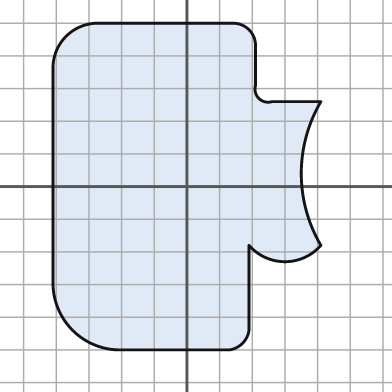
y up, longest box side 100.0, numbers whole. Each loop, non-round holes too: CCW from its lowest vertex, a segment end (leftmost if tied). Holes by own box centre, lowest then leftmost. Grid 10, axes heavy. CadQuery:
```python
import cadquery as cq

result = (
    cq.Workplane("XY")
    .moveTo(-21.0, -50.0)
    .lineTo(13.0, -50.0)
    .threePointArc((17.0, -48.0), (19.0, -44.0))
    .lineTo(19.0, -18.0)
    .threePointArc((30.0, -23.0), (41.0, -18.0))
    .threePointArc((35.0, 4.0), (41.0, 26.0))
    .lineTo(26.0, 26.0)
    .threePointArc((22.0, 27.0), (21.0, 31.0))
    .lineTo(21.0, 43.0)
    .threePointArc((19.0, 48.0), (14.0, 50.0))
    .lineTo(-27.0, 50.0)
    .threePointArc((-37.0, 46.0), (-41.0, 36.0))
    .lineTo(-41.0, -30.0)
    .threePointArc((-35.0, -44.0), (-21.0, -50.0))
    .close()
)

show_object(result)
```